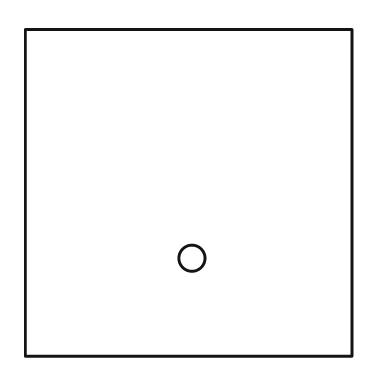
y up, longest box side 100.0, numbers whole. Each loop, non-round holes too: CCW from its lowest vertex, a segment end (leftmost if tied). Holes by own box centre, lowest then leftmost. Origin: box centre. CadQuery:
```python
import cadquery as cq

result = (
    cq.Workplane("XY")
    .moveTo(-50.0, -50.0)
    .lineTo(50.0, -50.0)
    .lineTo(50.0, 50.0)
    .lineTo(-50.0, 50.0)
    .close()
    .moveTo(1.0, -20.0)
    .circle(4.0)
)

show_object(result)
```